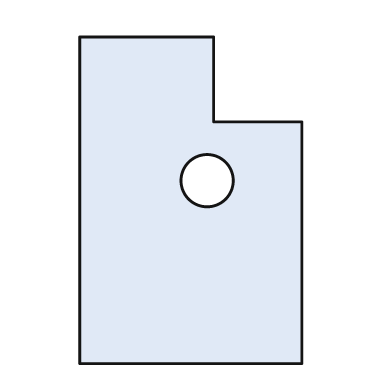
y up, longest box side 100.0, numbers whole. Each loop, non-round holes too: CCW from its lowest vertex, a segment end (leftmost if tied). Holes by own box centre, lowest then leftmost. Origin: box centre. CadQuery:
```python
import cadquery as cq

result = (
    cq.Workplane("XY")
    .moveTo(-34.0, -50.0)
    .lineTo(34.0, -50.0)
    .lineTo(34.0, 24.0)
    .lineTo(7.0, 24.0)
    .lineTo(7.0, 50.0)
    .lineTo(-34.0, 50.0)
    .close()
    .moveTo(5.0, 6.0)
    .circle(8.0)
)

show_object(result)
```